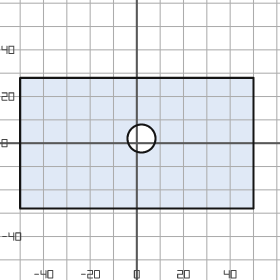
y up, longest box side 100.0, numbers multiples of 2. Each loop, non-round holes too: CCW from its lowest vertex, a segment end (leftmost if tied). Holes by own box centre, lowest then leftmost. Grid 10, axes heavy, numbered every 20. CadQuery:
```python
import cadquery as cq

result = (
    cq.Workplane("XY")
    .moveTo(-50.0, -28.0)
    .lineTo(50.0, -28.0)
    .lineTo(50.0, 28.0)
    .lineTo(-50.0, 28.0)
    .close()
    .moveTo(2.0, 2.0)
    .circle(6.0)
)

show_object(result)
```